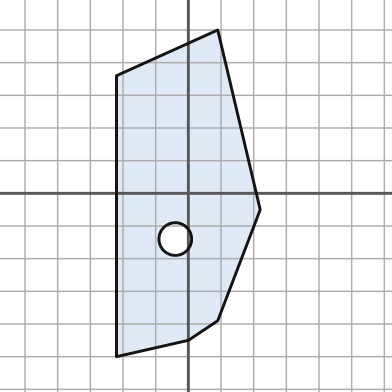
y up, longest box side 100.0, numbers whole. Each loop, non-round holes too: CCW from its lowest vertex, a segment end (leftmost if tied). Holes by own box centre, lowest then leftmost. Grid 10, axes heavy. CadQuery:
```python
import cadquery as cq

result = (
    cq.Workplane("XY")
    .moveTo(-22.0, -50.0)
    .lineTo(0.0, -45.0)
    .lineTo(9.0, -39.0)
    .lineTo(22.0, -5.0)
    .lineTo(9.0, 50.0)
    .lineTo(-22.0, 36.0)
    .close()
    .moveTo(-4.0, -14.0)
    .circle(5.0)
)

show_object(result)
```